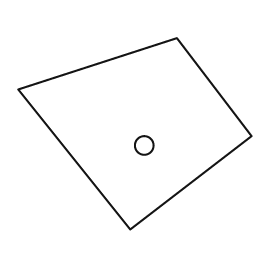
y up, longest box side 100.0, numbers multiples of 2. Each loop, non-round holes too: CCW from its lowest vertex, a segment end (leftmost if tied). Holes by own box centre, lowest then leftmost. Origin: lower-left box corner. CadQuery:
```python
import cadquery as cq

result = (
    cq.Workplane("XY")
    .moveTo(48.0, 0.0)
    .lineTo(100.0, 40.0)
    .lineTo(68.0, 82.0)
    .lineTo(0.0, 60.0)
    .close()
    .moveTo(54.0, 36.0)
    .circle(4.0)
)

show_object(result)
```